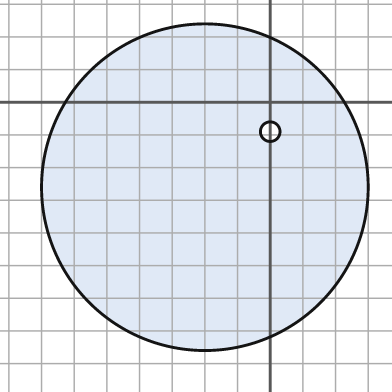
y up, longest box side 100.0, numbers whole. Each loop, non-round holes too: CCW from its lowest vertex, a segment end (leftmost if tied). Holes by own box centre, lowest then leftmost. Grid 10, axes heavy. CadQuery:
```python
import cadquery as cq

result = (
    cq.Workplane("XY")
    .moveTo(-20.0, -26.0)
    .circle(50.0)
    .moveTo(0.0, -9.0)
    .circle(3.0)
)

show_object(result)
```